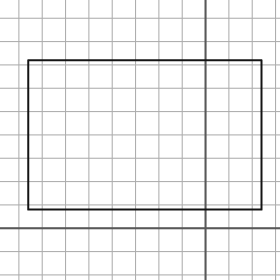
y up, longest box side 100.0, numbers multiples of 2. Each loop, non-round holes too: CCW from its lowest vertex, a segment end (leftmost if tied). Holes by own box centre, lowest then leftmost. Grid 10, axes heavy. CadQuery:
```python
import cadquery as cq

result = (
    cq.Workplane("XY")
    .moveTo(-76.0, 8.0)
    .lineTo(24.0, 8.0)
    .lineTo(24.0, 72.0)
    .lineTo(-76.0, 72.0)
    .close()
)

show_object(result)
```